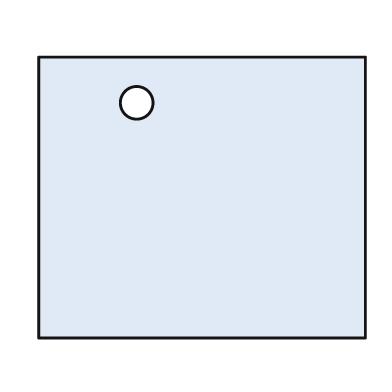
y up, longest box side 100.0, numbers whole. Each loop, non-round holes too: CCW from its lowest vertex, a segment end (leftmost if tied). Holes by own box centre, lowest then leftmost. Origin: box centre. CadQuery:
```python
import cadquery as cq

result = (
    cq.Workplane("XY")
    .moveTo(-50.0, -43.0)
    .lineTo(50.0, -43.0)
    .lineTo(50.0, 43.0)
    .lineTo(-50.0, 43.0)
    .close()
    .moveTo(-20.0, 29.0)
    .circle(5.0)
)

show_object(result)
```